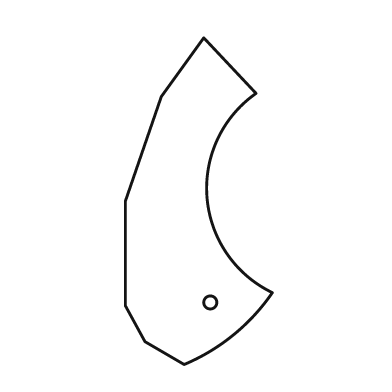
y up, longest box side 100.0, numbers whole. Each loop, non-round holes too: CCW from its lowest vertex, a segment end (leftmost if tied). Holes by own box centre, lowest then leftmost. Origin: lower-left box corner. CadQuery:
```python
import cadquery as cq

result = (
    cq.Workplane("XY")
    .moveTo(18.0, 0.0)
    .threePointArc((33.0, 9.0), (45.0, 22.0))
    .threePointArc((25.0, 51.0), (40.0, 83.0))
    .lineTo(24.0, 100.0)
    .lineTo(11.0, 82.0)
    .lineTo(0.0, 50.0)
    .lineTo(0.0, 18.0)
    .lineTo(6.0, 7.0)
    .close()
    .moveTo(26.0, 19.0)
    .circle(2.0)
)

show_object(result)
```